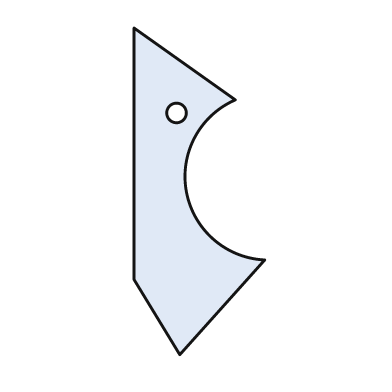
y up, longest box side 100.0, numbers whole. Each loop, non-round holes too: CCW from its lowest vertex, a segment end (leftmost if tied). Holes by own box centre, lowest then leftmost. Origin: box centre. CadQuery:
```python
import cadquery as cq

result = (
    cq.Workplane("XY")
    .moveTo(-6.0, -50.0)
    .lineTo(20.0, -21.0)
    .threePointArc((-4.0, 0.0), (11.0, 28.0))
    .lineTo(-20.0, 50.0)
    .lineTo(-20.0, -27.0)
    .close()
    .moveTo(-7.0, 24.0)
    .circle(3.0)
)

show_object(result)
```